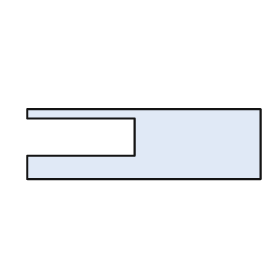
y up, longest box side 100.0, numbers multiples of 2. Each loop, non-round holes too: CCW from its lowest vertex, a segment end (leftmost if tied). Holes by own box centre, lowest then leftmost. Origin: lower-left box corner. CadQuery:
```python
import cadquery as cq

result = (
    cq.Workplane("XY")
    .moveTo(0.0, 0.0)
    .lineTo(100.0, 0.0)
    .lineTo(100.0, 30.0)
    .lineTo(0.0, 30.0)
    .lineTo(0.0, 26.0)
    .lineTo(46.0, 26.0)
    .lineTo(46.0, 10.0)
    .lineTo(0.0, 10.0)
    .close()
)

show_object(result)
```